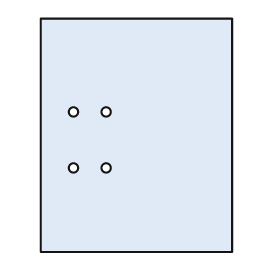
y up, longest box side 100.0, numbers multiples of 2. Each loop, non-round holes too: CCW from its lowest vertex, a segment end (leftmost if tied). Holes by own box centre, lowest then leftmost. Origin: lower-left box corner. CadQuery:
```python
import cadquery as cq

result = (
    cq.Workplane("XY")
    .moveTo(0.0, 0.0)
    .lineTo(82.0, 0.0)
    .lineTo(82.0, 100.0)
    .lineTo(0.0, 100.0)
    .close()
    .moveTo(14.0, 36.0)
    .circle(2.0)
    .moveTo(28.0, 36.0)
    .circle(2.0)
    .moveTo(14.0, 60.0)
    .circle(2.0)
    .moveTo(28.0, 60.0)
    .circle(2.0)
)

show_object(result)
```